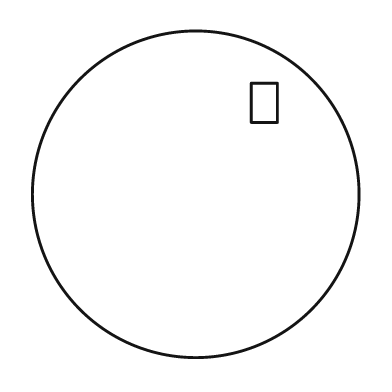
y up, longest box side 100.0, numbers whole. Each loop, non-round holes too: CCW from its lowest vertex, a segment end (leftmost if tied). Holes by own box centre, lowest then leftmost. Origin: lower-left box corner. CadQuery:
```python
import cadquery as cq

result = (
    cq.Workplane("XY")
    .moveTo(50.0, 50.0)
    .circle(50.0)
    .moveTo(67.0, 72.0)
    .lineTo(75.0, 72.0)
    .lineTo(75.0, 84.0)
    .lineTo(67.0, 84.0)
    .close()
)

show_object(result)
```